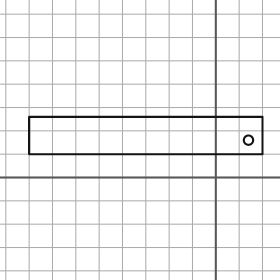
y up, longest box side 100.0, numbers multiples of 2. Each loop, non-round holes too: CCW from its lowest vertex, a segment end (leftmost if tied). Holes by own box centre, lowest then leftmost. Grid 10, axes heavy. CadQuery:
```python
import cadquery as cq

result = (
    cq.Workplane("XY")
    .moveTo(-80.0, 10.0)
    .lineTo(20.0, 10.0)
    .lineTo(20.0, 26.0)
    .lineTo(-80.0, 26.0)
    .close()
    .moveTo(14.0, 16.0)
    .circle(2.0)
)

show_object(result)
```